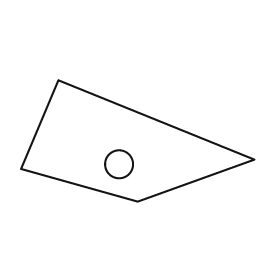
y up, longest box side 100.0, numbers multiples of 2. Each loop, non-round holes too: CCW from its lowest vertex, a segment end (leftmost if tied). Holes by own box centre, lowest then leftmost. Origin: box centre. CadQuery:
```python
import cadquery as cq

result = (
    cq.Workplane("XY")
    .moveTo(0.0, -26.0)
    .lineTo(50.0, -8.0)
    .lineTo(-34.0, 26.0)
    .lineTo(-50.0, -12.0)
    .close()
    .moveTo(-8.0, -10.0)
    .circle(6.0)
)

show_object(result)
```